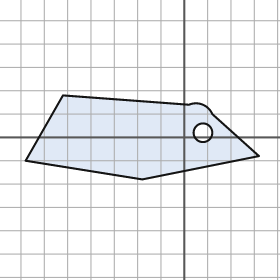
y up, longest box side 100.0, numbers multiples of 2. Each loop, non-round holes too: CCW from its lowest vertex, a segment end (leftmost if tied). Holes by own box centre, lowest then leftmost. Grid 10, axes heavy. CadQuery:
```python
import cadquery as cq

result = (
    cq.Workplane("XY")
    .moveTo(-18.0, -18.0)
    .lineTo(32.0, -8.0)
    .lineTo(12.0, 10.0)
    .threePointArc((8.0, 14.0), (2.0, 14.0))
    .lineTo(-52.0, 18.0)
    .lineTo(-68.0, -10.0)
    .close()
    .moveTo(8.0, 2.0)
    .circle(4.0)
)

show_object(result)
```